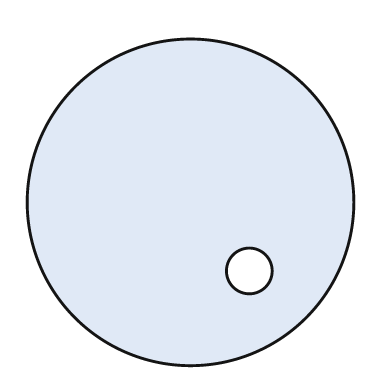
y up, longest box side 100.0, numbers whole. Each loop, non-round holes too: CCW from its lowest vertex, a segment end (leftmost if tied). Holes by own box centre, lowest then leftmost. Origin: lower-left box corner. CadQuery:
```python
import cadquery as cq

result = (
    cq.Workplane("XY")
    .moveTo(50.0, 50.0)
    .circle(50.0)
    .moveTo(68.0, 29.0)
    .circle(7.0)
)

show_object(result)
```